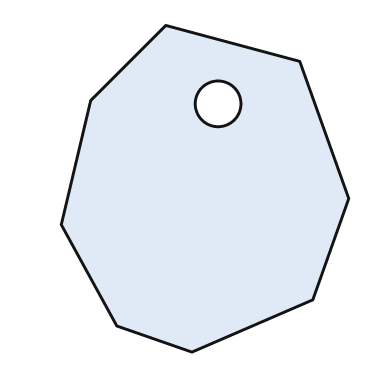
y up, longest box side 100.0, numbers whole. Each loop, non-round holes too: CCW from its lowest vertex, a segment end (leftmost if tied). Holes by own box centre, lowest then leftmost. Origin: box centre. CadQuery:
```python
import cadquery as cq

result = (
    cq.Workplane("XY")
    .moveTo(-4.0, -50.0)
    .lineTo(33.0, -34.0)
    .lineTo(44.0, -3.0)
    .lineTo(29.0, 39.0)
    .lineTo(-12.0, 50.0)
    .lineTo(-35.0, 27.0)
    .lineTo(-44.0, -11.0)
    .lineTo(-27.0, -42.0)
    .close()
    .moveTo(4.0, 26.0)
    .circle(7.0)
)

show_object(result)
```